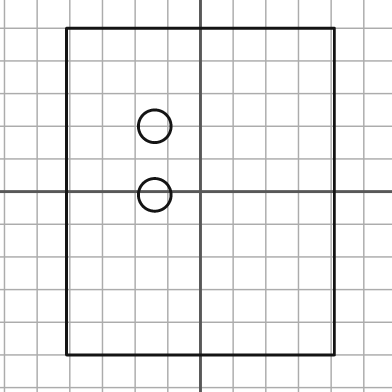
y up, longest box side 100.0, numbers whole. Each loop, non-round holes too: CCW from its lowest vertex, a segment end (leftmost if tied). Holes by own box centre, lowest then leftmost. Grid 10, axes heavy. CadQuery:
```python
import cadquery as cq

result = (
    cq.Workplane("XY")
    .moveTo(-41.0, -50.0)
    .lineTo(41.0, -50.0)
    .lineTo(41.0, 50.0)
    .lineTo(-41.0, 50.0)
    .close()
    .moveTo(-14.0, -1.0)
    .circle(5.0)
    .moveTo(-14.0, 20.0)
    .circle(5.0)
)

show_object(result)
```